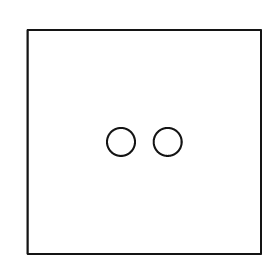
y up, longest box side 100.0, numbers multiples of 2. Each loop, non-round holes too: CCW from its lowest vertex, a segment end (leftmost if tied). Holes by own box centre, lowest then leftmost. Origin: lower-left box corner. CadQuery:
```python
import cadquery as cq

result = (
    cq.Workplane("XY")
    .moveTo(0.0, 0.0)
    .lineTo(100.0, 0.0)
    .lineTo(100.0, 96.0)
    .lineTo(0.0, 96.0)
    .close()
    .moveTo(40.0, 48.0)
    .circle(6.0)
    .moveTo(60.0, 48.0)
    .circle(6.0)
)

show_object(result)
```